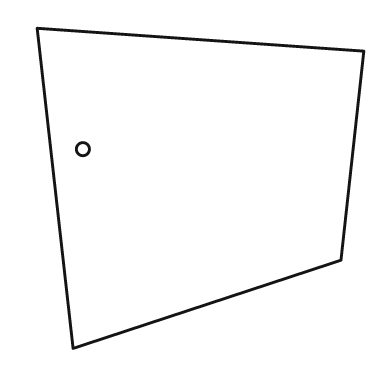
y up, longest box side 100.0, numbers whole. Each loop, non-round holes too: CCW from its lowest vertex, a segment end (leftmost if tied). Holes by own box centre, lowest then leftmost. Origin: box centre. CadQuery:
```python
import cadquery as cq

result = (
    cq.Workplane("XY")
    .moveTo(-39.0, -49.0)
    .lineTo(43.0, -22.0)
    .lineTo(50.0, 42.0)
    .lineTo(-50.0, 49.0)
    .close()
    .moveTo(-36.0, 12.0)
    .circle(2.0)
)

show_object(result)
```